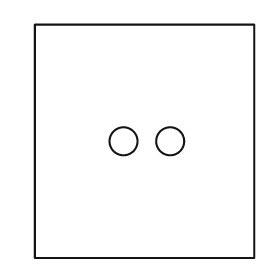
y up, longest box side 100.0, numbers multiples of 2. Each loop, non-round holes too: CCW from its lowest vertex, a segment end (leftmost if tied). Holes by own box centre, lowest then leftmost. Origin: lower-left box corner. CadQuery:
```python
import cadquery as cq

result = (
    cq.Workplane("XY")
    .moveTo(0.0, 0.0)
    .lineTo(94.0, 0.0)
    .lineTo(94.0, 100.0)
    .lineTo(0.0, 100.0)
    .close()
    .moveTo(38.0, 50.0)
    .circle(6.0)
    .moveTo(58.0, 50.0)
    .circle(6.0)
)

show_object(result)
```